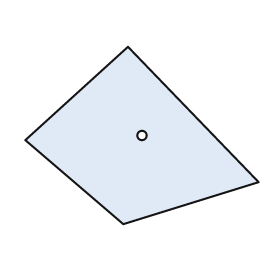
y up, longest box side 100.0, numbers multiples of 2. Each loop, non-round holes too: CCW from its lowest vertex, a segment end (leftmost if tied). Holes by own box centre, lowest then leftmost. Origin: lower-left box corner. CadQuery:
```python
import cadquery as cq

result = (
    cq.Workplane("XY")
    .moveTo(42.0, 0.0)
    .lineTo(100.0, 18.0)
    .lineTo(44.0, 76.0)
    .lineTo(0.0, 36.0)
    .close()
    .moveTo(50.0, 38.0)
    .circle(2.0)
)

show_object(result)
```